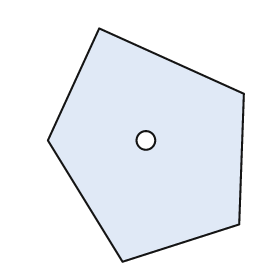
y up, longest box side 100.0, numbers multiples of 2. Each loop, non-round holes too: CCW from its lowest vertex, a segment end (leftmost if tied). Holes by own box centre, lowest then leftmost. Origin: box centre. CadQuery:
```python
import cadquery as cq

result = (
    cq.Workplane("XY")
    .moveTo(-10.0, -50.0)
    .lineTo(40.0, -34.0)
    .lineTo(42.0, 22.0)
    .lineTo(-20.0, 50.0)
    .lineTo(-42.0, 2.0)
    .close()
    .moveTo(0.0, 2.0)
    .circle(4.0)
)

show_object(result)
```